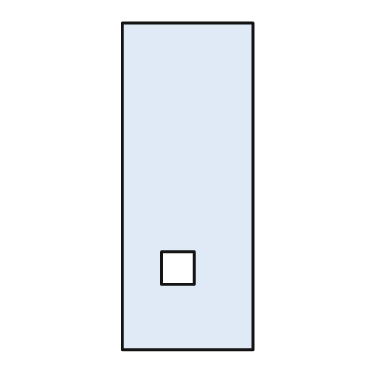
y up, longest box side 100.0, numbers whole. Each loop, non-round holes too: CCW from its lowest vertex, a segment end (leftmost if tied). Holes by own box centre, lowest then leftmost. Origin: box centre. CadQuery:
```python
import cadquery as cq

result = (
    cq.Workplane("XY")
    .moveTo(-20.0, -50.0)
    .lineTo(20.0, -50.0)
    .lineTo(20.0, 50.0)
    .lineTo(-20.0, 50.0)
    .close()
    .moveTo(-8.0, -30.0)
    .lineTo(2.0, -30.0)
    .lineTo(2.0, -20.0)
    .lineTo(-8.0, -20.0)
    .close()
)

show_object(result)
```